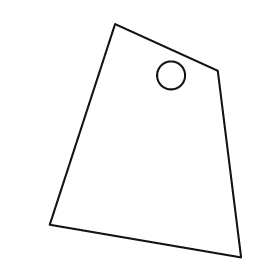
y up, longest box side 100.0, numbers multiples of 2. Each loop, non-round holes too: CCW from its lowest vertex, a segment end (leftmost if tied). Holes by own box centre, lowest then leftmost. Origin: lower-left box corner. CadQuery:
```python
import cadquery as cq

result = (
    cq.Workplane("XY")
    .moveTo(82.0, 0.0)
    .lineTo(72.0, 80.0)
    .lineTo(28.0, 100.0)
    .lineTo(0.0, 14.0)
    .close()
    .moveTo(52.0, 78.0)
    .circle(6.0)
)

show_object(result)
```